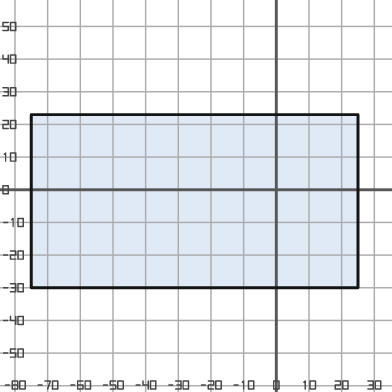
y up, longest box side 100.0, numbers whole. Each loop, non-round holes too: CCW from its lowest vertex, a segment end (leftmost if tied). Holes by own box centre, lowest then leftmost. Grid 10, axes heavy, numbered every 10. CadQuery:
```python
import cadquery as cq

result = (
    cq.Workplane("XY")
    .moveTo(-75.0, -30.0)
    .lineTo(25.0, -30.0)
    .lineTo(25.0, 23.0)
    .lineTo(-75.0, 23.0)
    .close()
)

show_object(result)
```